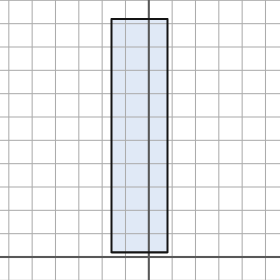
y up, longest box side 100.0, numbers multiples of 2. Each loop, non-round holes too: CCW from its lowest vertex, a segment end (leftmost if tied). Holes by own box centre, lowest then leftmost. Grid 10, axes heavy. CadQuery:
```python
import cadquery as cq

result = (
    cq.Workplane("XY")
    .moveTo(-16.0, 2.0)
    .lineTo(8.0, 2.0)
    .lineTo(8.0, 102.0)
    .lineTo(-16.0, 102.0)
    .close()
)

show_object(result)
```